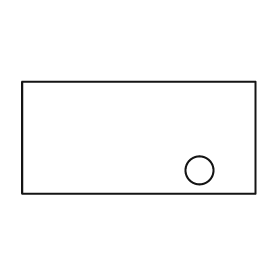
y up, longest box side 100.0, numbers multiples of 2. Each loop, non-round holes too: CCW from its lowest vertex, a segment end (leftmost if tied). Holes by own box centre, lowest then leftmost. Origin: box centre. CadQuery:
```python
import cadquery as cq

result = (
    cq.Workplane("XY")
    .moveTo(-50.0, -24.0)
    .lineTo(50.0, -24.0)
    .lineTo(50.0, 24.0)
    .lineTo(-50.0, 24.0)
    .close()
    .moveTo(26.0, -14.0)
    .circle(6.0)
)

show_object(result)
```